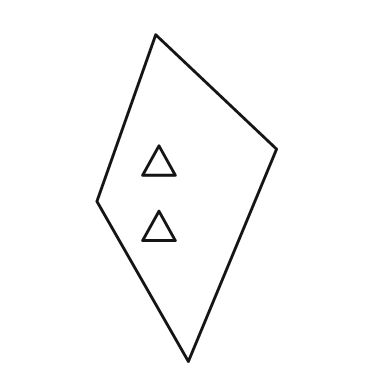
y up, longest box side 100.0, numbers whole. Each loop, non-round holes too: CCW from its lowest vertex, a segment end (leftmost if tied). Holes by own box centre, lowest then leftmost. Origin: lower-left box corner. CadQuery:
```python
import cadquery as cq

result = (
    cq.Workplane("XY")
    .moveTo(28.0, 0.0)
    .lineTo(55.0, 65.0)
    .lineTo(18.0, 100.0)
    .lineTo(0.0, 49.0)
    .close()
    .moveTo(14.0, 37.0)
    .lineTo(24.0, 37.0)
    .lineTo(19.0, 46.0)
    .close()
    .moveTo(14.0, 57.0)
    .lineTo(24.0, 57.0)
    .lineTo(19.0, 66.0)
    .close()
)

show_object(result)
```